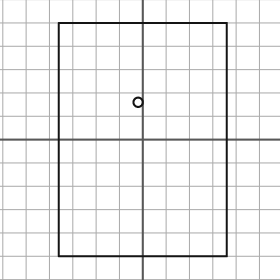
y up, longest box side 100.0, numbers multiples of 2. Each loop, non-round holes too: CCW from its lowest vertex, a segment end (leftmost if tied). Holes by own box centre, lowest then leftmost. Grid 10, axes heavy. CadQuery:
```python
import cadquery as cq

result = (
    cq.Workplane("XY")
    .moveTo(-36.0, -50.0)
    .lineTo(36.0, -50.0)
    .lineTo(36.0, 50.0)
    .lineTo(-36.0, 50.0)
    .close()
    .moveTo(-2.0, 16.0)
    .circle(2.0)
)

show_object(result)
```